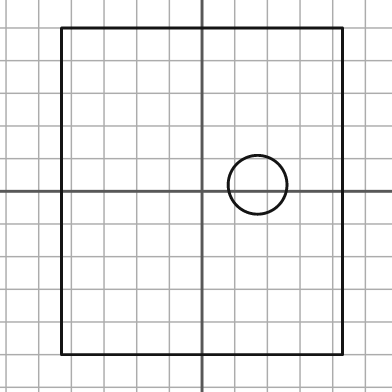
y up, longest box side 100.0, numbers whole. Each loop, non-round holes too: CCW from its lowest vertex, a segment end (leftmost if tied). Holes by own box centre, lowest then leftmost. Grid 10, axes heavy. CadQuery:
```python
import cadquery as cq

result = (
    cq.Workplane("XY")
    .moveTo(-43.0, -50.0)
    .lineTo(43.0, -50.0)
    .lineTo(43.0, 50.0)
    .lineTo(-43.0, 50.0)
    .close()
    .moveTo(17.0, 2.0)
    .circle(9.0)
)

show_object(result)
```